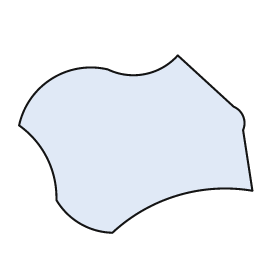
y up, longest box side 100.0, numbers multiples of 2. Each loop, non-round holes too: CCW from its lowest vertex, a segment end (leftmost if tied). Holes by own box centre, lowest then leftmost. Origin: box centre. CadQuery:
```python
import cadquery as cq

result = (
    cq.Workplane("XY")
    .moveTo(-10.0, -38.0)
    .threePointArc((18.0, -22.0), (50.0, -20.0))
    .lineTo(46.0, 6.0)
    .threePointArc((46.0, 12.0), (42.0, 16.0))
    .lineTo(18.0, 38.0)
    .threePointArc((4.0, 30.0), (-12.0, 32.0))
    .threePointArc((-36.0, 28.0), (-50.0, 8.0))
    .threePointArc((-38.0, -6.0), (-34.0, -24.0))
    .threePointArc((-24.0, -34.0), (-10.0, -38.0))
    .close()
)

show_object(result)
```